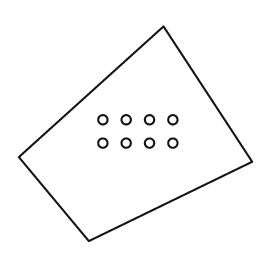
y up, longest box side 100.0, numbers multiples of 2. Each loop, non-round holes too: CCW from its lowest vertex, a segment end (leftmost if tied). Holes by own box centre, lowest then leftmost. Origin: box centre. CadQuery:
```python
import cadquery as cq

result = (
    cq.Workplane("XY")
    .moveTo(-20.0, -46.0)
    .lineTo(50.0, -12.0)
    .lineTo(12.0, 46.0)
    .lineTo(-50.0, -10.0)
    .close()
    .moveTo(-14.0, -4.0)
    .circle(2.0)
    .moveTo(-4.0, -4.0)
    .circle(2.0)
    .moveTo(6.0, -4.0)
    .circle(2.0)
    .moveTo(16.0, -4.0)
    .circle(2.0)
    .moveTo(-14.0, 6.0)
    .circle(2.0)
    .moveTo(-4.0, 6.0)
    .circle(2.0)
    .moveTo(6.0, 6.0)
    .circle(2.0)
    .moveTo(16.0, 6.0)
    .circle(2.0)
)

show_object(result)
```